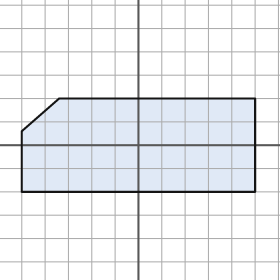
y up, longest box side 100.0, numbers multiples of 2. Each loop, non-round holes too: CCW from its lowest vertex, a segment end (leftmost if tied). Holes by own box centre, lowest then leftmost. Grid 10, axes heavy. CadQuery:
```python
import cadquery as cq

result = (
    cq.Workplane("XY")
    .moveTo(-50.0, -20.0)
    .lineTo(50.0, -20.0)
    .lineTo(50.0, 20.0)
    .lineTo(-34.0, 20.0)
    .lineTo(-50.0, 6.0)
    .close()
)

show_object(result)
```